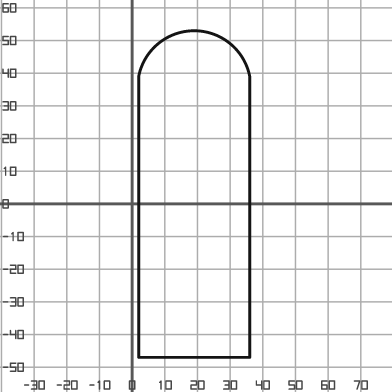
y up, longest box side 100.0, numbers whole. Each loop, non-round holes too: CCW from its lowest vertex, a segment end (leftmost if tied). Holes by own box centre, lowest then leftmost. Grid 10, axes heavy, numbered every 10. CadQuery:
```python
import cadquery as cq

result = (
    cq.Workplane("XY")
    .moveTo(2.0, -47.0)
    .lineTo(36.0, -47.0)
    .lineTo(36.0, 39.0)
    .threePointArc((19.0, 53.0), (2.0, 39.0))
    .close()
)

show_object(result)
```